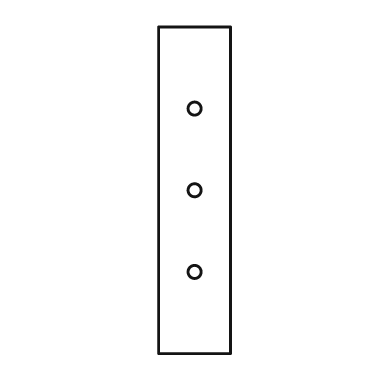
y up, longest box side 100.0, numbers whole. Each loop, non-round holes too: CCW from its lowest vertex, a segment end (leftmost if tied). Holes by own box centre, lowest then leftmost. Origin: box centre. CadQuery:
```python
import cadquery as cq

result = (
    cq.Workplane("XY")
    .moveTo(-11.0, -50.0)
    .lineTo(11.0, -50.0)
    .lineTo(11.0, 50.0)
    .lineTo(-11.0, 50.0)
    .close()
    .moveTo(0.0, -25.0)
    .circle(2.0)
    .moveTo(0.0, 0.0)
    .circle(2.0)
    .moveTo(0.0, 25.0)
    .circle(2.0)
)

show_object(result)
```